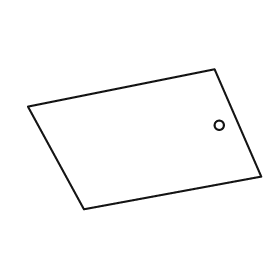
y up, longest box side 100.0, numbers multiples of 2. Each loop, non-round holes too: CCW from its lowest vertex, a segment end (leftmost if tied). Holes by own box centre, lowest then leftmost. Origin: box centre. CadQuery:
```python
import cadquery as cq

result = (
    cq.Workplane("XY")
    .moveTo(-26.0, -30.0)
    .lineTo(50.0, -16.0)
    .lineTo(30.0, 30.0)
    .lineTo(-50.0, 14.0)
    .close()
    .moveTo(32.0, 6.0)
    .circle(2.0)
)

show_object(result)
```